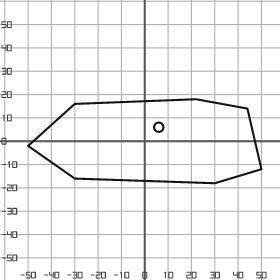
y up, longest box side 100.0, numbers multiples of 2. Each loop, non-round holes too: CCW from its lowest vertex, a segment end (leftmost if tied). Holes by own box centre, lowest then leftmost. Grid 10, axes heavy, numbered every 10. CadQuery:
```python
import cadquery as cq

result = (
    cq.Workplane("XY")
    .moveTo(30.0, -18.0)
    .lineTo(50.0, -12.0)
    .lineTo(44.0, 14.0)
    .lineTo(22.0, 18.0)
    .lineTo(-30.0, 16.0)
    .lineTo(-50.0, -2.0)
    .lineTo(-30.0, -16.0)
    .close()
    .moveTo(6.0, 6.0)
    .circle(2.0)
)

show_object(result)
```